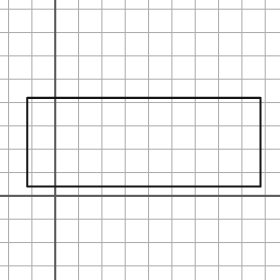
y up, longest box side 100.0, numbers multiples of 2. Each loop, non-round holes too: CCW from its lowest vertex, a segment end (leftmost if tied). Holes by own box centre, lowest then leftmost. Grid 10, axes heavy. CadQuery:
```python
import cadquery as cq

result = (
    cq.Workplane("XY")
    .moveTo(-12.0, 4.0)
    .lineTo(88.0, 4.0)
    .lineTo(88.0, 42.0)
    .lineTo(-12.0, 42.0)
    .close()
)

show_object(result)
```